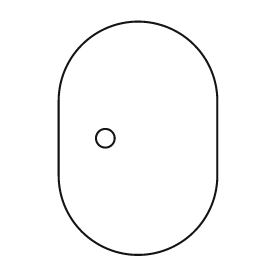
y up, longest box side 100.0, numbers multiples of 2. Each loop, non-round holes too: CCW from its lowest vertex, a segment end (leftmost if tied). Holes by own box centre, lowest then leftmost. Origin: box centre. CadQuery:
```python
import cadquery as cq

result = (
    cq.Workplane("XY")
    .moveTo(-34.0, -16.0)
    .threePointArc((0.0, -50.0), (34.0, -16.0))
    .lineTo(34.0, 16.0)
    .threePointArc((0.0, 50.0), (-34.0, 16.0))
    .close()
    .moveTo(-14.0, 0.0)
    .circle(4.0)
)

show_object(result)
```